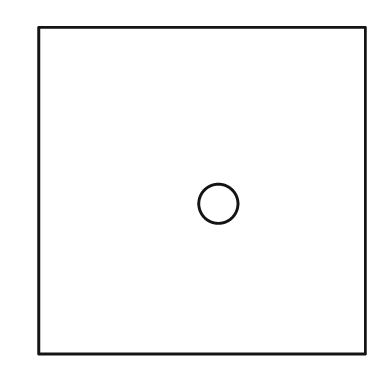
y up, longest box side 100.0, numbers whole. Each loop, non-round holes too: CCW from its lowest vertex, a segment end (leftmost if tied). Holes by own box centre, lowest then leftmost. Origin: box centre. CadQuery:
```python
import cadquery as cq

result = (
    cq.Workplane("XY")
    .moveTo(-50.0, -50.0)
    .lineTo(50.0, -50.0)
    .lineTo(50.0, 50.0)
    .lineTo(-50.0, 50.0)
    .close()
    .moveTo(5.0, -4.0)
    .circle(6.0)
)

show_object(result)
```